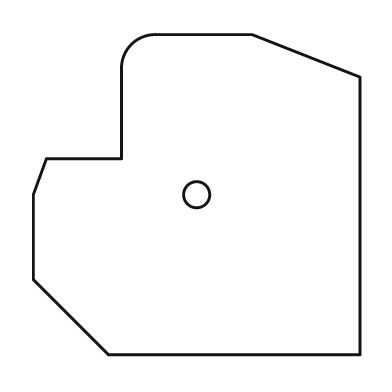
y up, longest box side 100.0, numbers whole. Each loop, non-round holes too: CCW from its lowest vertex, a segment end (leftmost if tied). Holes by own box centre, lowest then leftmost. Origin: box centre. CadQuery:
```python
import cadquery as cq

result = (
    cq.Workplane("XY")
    .moveTo(-27.0, -49.0)
    .lineTo(50.0, -49.0)
    .lineTo(50.0, 36.0)
    .lineTo(17.0, 49.0)
    .lineTo(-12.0, 49.0)
    .threePointArc((-20.0, 46.0), (-23.0, 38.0))
    .lineTo(-23.0, 11.0)
    .lineTo(-46.0, 11.0)
    .lineTo(-50.0, 0.0)
    .lineTo(-50.0, -26.0)
    .close()
    .moveTo(0.0, 0.0)
    .circle(4.0)
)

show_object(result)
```